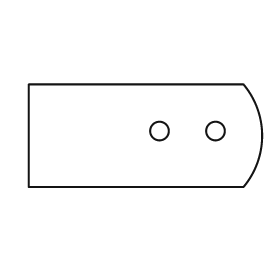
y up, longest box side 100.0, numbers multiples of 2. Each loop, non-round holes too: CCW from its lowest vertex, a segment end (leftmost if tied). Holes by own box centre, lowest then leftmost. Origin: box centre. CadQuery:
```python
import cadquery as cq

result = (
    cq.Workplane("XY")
    .moveTo(-50.0, -22.0)
    .lineTo(42.0, -22.0)
    .threePointArc((50.0, 0.0), (42.0, 22.0))
    .lineTo(-50.0, 22.0)
    .close()
    .moveTo(6.0, 2.0)
    .circle(4.0)
    .moveTo(30.0, 2.0)
    .circle(4.0)
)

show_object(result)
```